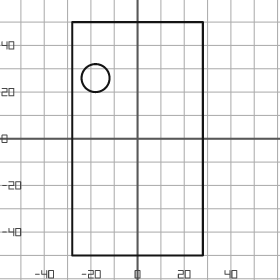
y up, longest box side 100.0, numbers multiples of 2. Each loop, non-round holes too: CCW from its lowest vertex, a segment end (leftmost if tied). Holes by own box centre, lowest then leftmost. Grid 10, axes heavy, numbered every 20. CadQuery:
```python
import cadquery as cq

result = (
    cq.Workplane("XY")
    .moveTo(-28.0, -50.0)
    .lineTo(28.0, -50.0)
    .lineTo(28.0, 50.0)
    .lineTo(-28.0, 50.0)
    .close()
    .moveTo(-18.0, 26.0)
    .circle(6.0)
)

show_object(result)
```